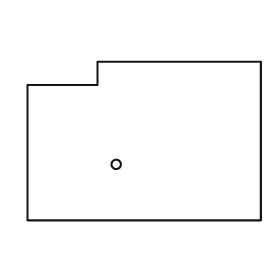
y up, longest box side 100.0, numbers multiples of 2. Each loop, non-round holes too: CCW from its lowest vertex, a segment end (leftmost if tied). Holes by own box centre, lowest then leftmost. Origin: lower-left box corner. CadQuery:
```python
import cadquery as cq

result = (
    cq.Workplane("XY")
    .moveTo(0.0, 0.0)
    .lineTo(100.0, 0.0)
    .lineTo(100.0, 68.0)
    .lineTo(30.0, 68.0)
    .lineTo(30.0, 58.0)
    .lineTo(0.0, 58.0)
    .close()
    .moveTo(38.0, 24.0)
    .circle(2.0)
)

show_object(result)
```